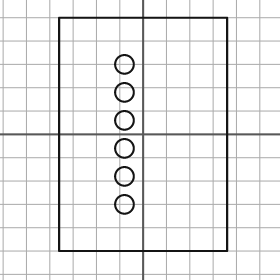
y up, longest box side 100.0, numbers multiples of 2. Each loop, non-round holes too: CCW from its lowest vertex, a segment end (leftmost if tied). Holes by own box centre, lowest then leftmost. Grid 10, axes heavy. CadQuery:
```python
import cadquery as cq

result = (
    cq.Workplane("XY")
    .moveTo(-36.0, -50.0)
    .lineTo(36.0, -50.0)
    .lineTo(36.0, 50.0)
    .lineTo(-36.0, 50.0)
    .close()
    .moveTo(-8.0, -30.0)
    .circle(4.0)
    .moveTo(-8.0, -18.0)
    .circle(4.0)
    .moveTo(-8.0, -6.0)
    .circle(4.0)
    .moveTo(-8.0, 6.0)
    .circle(4.0)
    .moveTo(-8.0, 18.0)
    .circle(4.0)
    .moveTo(-8.0, 30.0)
    .circle(4.0)
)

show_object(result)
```